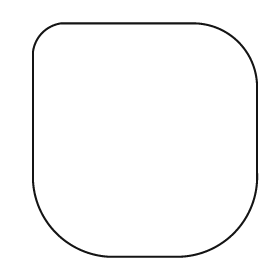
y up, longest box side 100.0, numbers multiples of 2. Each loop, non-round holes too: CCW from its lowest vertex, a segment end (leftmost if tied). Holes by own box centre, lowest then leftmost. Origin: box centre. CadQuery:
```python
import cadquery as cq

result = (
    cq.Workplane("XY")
    .moveTo(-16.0, -50.0)
    .lineTo(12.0, -50.0)
    .threePointArc((38.0, -40.0), (48.0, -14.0))
    .lineTo(48.0, 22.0)
    .threePointArc((40.0, 42.0), (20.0, 50.0))
    .lineTo(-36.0, 50.0)
    .threePointArc((-44.0, 46.0), (-48.0, 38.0))
    .lineTo(-48.0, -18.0)
    .threePointArc((-38.0, -40.0), (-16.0, -50.0))
    .close()
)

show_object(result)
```